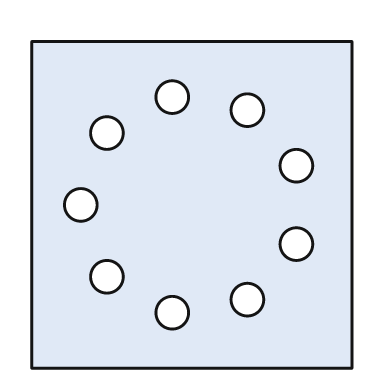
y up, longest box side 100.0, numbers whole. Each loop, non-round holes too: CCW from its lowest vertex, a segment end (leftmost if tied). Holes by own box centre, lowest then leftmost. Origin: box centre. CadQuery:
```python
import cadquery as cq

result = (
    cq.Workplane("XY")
    .moveTo(-49.0, -50.0)
    .lineTo(49.0, -50.0)
    .lineTo(49.0, 50.0)
    .lineTo(-49.0, 50.0)
    .close()
    .moveTo(-6.0, -33.0)
    .circle(5.0)
    .moveTo(17.0, -29.0)
    .circle(5.0)
    .moveTo(-26.0, -22.0)
    .circle(5.0)
    .moveTo(32.0, -12.0)
    .circle(5.0)
    .moveTo(-34.0, 0.0)
    .circle(5.0)
    .moveTo(32.0, 12.0)
    .circle(5.0)
    .moveTo(-26.0, 22.0)
    .circle(5.0)
    .moveTo(17.0, 29.0)
    .circle(5.0)
    .moveTo(-6.0, 33.0)
    .circle(5.0)
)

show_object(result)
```